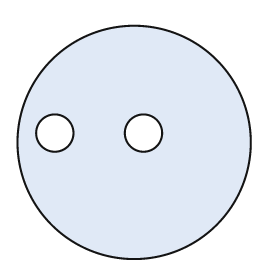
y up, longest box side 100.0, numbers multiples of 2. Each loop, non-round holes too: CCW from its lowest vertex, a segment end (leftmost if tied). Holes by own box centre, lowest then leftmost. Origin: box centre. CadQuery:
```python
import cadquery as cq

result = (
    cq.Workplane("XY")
    .moveTo(0.0, 0.0)
    .circle(50.0)
    .moveTo(-34.0, 4.0)
    .circle(8.0)
    .moveTo(4.0, 4.0)
    .circle(8.0)
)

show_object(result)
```